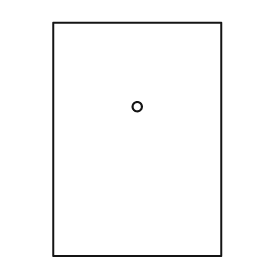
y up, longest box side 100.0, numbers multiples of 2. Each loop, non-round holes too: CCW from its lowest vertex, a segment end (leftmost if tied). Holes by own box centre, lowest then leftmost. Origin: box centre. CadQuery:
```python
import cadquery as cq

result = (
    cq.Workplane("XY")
    .moveTo(-36.0, -50.0)
    .lineTo(36.0, -50.0)
    .lineTo(36.0, 50.0)
    .lineTo(-36.0, 50.0)
    .close()
    .moveTo(0.0, 14.0)
    .circle(2.0)
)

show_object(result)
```